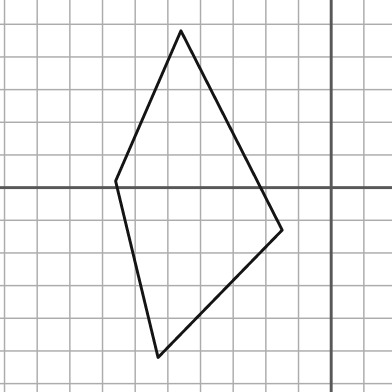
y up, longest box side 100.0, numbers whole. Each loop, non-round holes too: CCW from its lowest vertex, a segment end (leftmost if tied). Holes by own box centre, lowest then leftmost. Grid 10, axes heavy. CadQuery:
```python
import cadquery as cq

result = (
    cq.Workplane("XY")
    .moveTo(-53.0, -52.0)
    .lineTo(-15.0, -13.0)
    .lineTo(-46.0, 48.0)
    .lineTo(-66.0, 2.0)
    .close()
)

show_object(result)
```